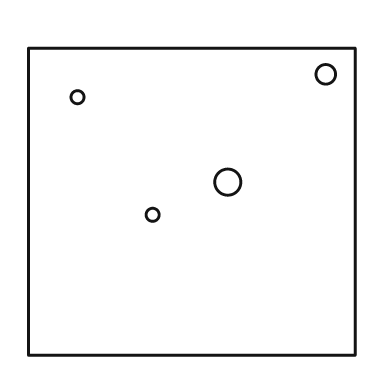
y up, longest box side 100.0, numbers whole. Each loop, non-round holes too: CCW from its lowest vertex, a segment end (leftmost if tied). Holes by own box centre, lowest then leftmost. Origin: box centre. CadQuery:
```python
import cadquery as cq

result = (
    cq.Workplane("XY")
    .moveTo(-50.0, -47.0)
    .lineTo(50.0, -47.0)
    .lineTo(50.0, 47.0)
    .lineTo(-50.0, 47.0)
    .close()
    .moveTo(-12.0, -4.0)
    .circle(2.0)
    .moveTo(11.0, 6.0)
    .circle(4.0)
    .moveTo(-35.0, 32.0)
    .circle(2.0)
    .moveTo(41.0, 39.0)
    .circle(3.0)
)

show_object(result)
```